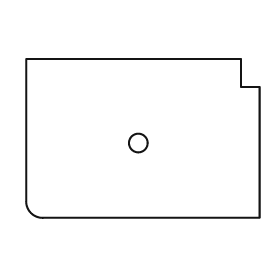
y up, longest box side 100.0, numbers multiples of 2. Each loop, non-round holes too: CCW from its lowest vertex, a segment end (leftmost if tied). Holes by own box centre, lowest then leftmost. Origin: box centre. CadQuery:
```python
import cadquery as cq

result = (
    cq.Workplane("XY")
    .moveTo(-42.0, -34.0)
    .lineTo(50.0, -34.0)
    .lineTo(50.0, 22.0)
    .lineTo(42.0, 22.0)
    .lineTo(42.0, 34.0)
    .lineTo(-50.0, 34.0)
    .lineTo(-50.0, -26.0)
    .threePointArc((-48.0, -32.0), (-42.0, -34.0))
    .close()
    .moveTo(-2.0, -2.0)
    .circle(4.0)
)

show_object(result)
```